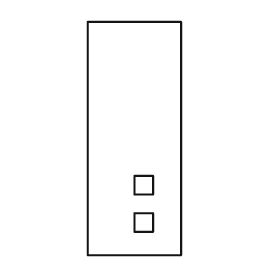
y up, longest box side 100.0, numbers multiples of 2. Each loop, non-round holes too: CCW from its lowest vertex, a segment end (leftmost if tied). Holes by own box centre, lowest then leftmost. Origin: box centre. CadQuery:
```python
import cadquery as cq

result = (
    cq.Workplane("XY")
    .moveTo(-20.0, -50.0)
    .lineTo(20.0, -50.0)
    .lineTo(20.0, 50.0)
    .lineTo(-20.0, 50.0)
    .close()
    .moveTo(0.0, -40.0)
    .lineTo(8.0, -40.0)
    .lineTo(8.0, -32.0)
    .lineTo(0.0, -32.0)
    .close()
    .moveTo(0.0, -24.0)
    .lineTo(8.0, -24.0)
    .lineTo(8.0, -16.0)
    .lineTo(0.0, -16.0)
    .close()
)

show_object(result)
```